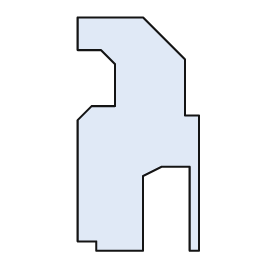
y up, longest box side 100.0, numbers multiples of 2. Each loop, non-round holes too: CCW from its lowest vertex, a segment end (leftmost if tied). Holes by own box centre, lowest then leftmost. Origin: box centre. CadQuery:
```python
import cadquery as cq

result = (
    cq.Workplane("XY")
    .moveTo(-18.0, -50.0)
    .lineTo(2.0, -50.0)
    .lineTo(2.0, -18.0)
    .lineTo(10.0, -14.0)
    .lineTo(22.0, -14.0)
    .lineTo(22.0, -50.0)
    .lineTo(26.0, -50.0)
    .lineTo(26.0, 8.0)
    .lineTo(20.0, 8.0)
    .lineTo(20.0, 32.0)
    .lineTo(2.0, 50.0)
    .lineTo(-26.0, 50.0)
    .lineTo(-26.0, 36.0)
    .lineTo(-16.0, 36.0)
    .lineTo(-10.0, 30.0)
    .lineTo(-10.0, 12.0)
    .lineTo(-20.0, 12.0)
    .lineTo(-26.0, 6.0)
    .lineTo(-26.0, -46.0)
    .lineTo(-18.0, -46.0)
    .close()
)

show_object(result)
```